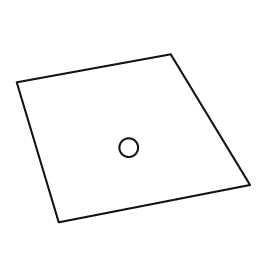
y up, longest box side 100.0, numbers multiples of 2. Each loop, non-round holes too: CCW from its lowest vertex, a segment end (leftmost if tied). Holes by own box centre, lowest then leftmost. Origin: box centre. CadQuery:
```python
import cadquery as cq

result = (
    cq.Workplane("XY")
    .moveTo(-32.0, -36.0)
    .lineTo(50.0, -20.0)
    .lineTo(16.0, 36.0)
    .lineTo(-50.0, 24.0)
    .close()
    .moveTo(-2.0, -4.0)
    .circle(4.0)
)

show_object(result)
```